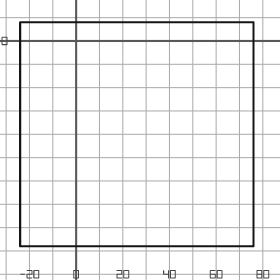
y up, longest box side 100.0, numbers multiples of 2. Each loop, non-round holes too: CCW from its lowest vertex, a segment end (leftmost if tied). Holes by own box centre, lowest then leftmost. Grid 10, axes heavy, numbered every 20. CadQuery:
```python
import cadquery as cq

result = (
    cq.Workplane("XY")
    .moveTo(-24.0, -88.0)
    .lineTo(76.0, -88.0)
    .lineTo(76.0, 8.0)
    .lineTo(-24.0, 8.0)
    .close()
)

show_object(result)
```